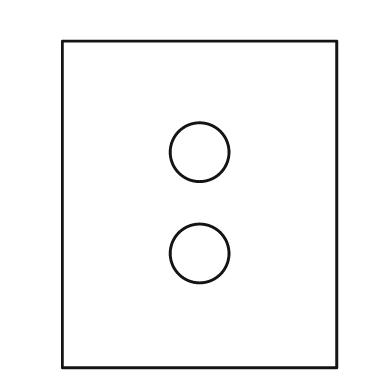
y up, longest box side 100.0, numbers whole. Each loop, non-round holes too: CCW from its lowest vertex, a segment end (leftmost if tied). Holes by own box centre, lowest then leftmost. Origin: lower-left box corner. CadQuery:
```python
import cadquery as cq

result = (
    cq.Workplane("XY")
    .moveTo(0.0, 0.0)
    .lineTo(84.0, 0.0)
    .lineTo(84.0, 100.0)
    .lineTo(0.0, 100.0)
    .close()
    .moveTo(42.0, 35.0)
    .circle(9.0)
    .moveTo(42.0, 66.0)
    .circle(9.0)
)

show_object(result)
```